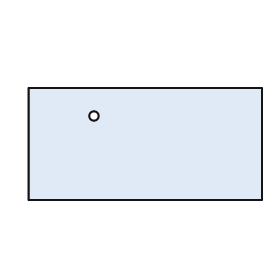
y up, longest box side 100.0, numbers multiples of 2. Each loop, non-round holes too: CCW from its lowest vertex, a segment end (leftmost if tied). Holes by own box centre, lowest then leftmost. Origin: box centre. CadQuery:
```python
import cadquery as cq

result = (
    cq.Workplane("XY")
    .moveTo(-50.0, -24.0)
    .lineTo(50.0, -24.0)
    .lineTo(50.0, 24.0)
    .lineTo(-50.0, 24.0)
    .close()
    .moveTo(-22.0, 12.0)
    .circle(2.0)
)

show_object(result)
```